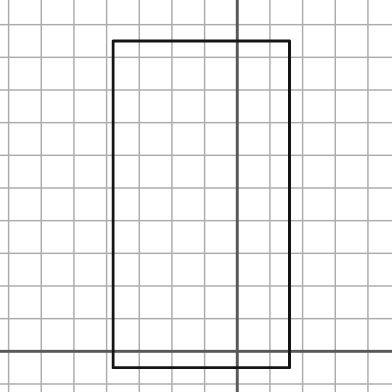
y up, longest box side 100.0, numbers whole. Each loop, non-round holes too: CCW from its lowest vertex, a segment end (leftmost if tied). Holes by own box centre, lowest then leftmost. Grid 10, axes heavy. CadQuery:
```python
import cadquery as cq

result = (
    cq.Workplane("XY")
    .moveTo(-38.0, -5.0)
    .lineTo(16.0, -5.0)
    .lineTo(16.0, 95.0)
    .lineTo(-38.0, 95.0)
    .close()
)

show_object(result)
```